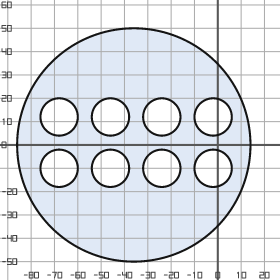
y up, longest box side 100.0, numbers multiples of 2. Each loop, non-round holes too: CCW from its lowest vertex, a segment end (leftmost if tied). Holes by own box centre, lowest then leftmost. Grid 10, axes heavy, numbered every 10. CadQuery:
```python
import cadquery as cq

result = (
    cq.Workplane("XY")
    .moveTo(-36.0, 0.0)
    .circle(50.0)
    .moveTo(-68.0, -10.0)
    .circle(8.0)
    .moveTo(-46.0, -10.0)
    .circle(8.0)
    .moveTo(-24.0, -10.0)
    .circle(8.0)
    .moveTo(-2.0, -10.0)
    .circle(8.0)
    .moveTo(-68.0, 12.0)
    .circle(8.0)
    .moveTo(-46.0, 12.0)
    .circle(8.0)
    .moveTo(-24.0, 12.0)
    .circle(8.0)
    .moveTo(-2.0, 12.0)
    .circle(8.0)
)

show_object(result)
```